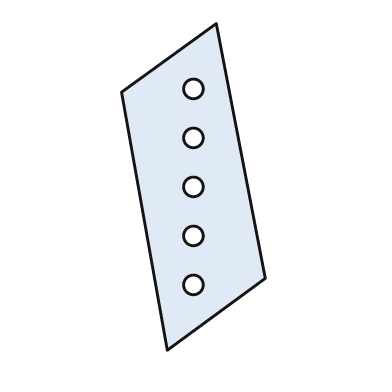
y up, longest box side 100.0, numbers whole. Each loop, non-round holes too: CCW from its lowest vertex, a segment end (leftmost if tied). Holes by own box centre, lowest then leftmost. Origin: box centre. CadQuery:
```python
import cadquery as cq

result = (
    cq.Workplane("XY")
    .moveTo(-8.0, -50.0)
    .lineTo(22.0, -28.0)
    .lineTo(7.0, 50.0)
    .lineTo(-22.0, 29.0)
    .close()
    .moveTo(0.0, -30.0)
    .circle(3.0)
    .moveTo(0.0, -15.0)
    .circle(3.0)
    .moveTo(0.0, 0.0)
    .circle(3.0)
    .moveTo(0.0, 15.0)
    .circle(3.0)
    .moveTo(0.0, 30.0)
    .circle(3.0)
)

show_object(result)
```